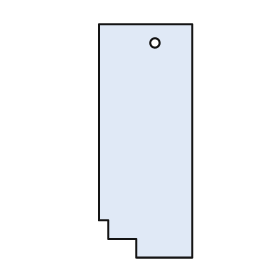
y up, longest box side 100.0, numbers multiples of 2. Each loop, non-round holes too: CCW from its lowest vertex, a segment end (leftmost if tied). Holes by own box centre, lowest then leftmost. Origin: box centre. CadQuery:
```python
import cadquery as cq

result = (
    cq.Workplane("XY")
    .moveTo(-4.0, -50.0)
    .lineTo(20.0, -50.0)
    .lineTo(20.0, 50.0)
    .lineTo(-20.0, 50.0)
    .lineTo(-20.0, -34.0)
    .lineTo(-16.0, -34.0)
    .lineTo(-16.0, -42.0)
    .lineTo(-4.0, -42.0)
    .close()
    .moveTo(4.0, 42.0)
    .circle(2.0)
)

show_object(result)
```